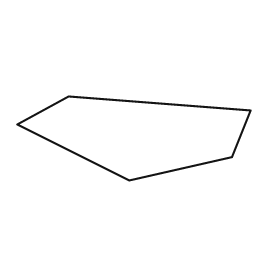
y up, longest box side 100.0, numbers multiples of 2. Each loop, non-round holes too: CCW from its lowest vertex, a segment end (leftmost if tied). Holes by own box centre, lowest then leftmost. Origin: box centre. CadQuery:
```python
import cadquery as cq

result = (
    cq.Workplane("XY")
    .moveTo(-2.0, -18.0)
    .lineTo(42.0, -8.0)
    .lineTo(50.0, 12.0)
    .lineTo(-28.0, 18.0)
    .lineTo(-50.0, 6.0)
    .close()
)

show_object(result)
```